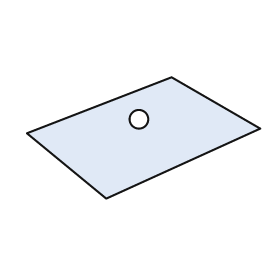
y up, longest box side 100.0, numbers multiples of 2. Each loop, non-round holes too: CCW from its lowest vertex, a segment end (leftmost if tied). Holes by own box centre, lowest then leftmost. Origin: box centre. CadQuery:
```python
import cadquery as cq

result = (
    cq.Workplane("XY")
    .moveTo(-16.0, -26.0)
    .lineTo(50.0, 4.0)
    .lineTo(12.0, 26.0)
    .lineTo(-50.0, 2.0)
    .close()
    .moveTo(-2.0, 8.0)
    .circle(4.0)
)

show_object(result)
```